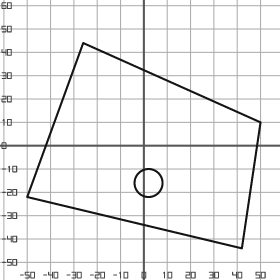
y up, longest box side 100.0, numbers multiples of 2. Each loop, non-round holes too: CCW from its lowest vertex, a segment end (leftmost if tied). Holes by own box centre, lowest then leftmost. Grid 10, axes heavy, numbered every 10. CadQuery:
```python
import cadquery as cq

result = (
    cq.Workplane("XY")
    .moveTo(42.0, -44.0)
    .lineTo(50.0, 10.0)
    .lineTo(-26.0, 44.0)
    .lineTo(-50.0, -22.0)
    .close()
    .moveTo(2.0, -16.0)
    .circle(6.0)
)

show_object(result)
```